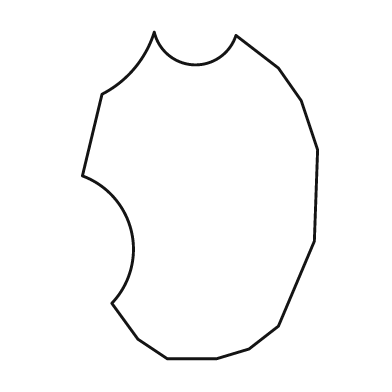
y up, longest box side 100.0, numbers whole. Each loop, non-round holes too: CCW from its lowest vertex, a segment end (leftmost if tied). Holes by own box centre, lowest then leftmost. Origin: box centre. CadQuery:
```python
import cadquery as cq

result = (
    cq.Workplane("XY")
    .moveTo(-10.0, -50.0)
    .lineTo(5.0, -50.0)
    .lineTo(15.0, -47.0)
    .lineTo(24.0, -40.0)
    .lineTo(35.0, -14.0)
    .lineTo(36.0, 14.0)
    .lineTo(31.0, 29.0)
    .lineTo(24.0, 39.0)
    .lineTo(11.0, 49.0)
    .threePointArc((-2.0, 40.0), (-14.0, 50.0))
    .threePointArc((-20.0, 39.0), (-30.0, 31.0))
    .lineTo(-36.0, 6.0)
    .threePointArc((-21.0, -11.0), (-27.0, -33.0))
    .lineTo(-19.0, -44.0)
    .close()
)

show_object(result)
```